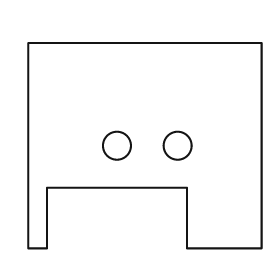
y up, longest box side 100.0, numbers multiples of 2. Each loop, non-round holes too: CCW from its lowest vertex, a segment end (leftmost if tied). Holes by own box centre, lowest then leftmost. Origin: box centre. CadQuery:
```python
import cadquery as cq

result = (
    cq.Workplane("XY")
    .moveTo(-50.0, -44.0)
    .lineTo(-42.0, -44.0)
    .lineTo(-42.0, -18.0)
    .lineTo(18.0, -18.0)
    .lineTo(18.0, -44.0)
    .lineTo(50.0, -44.0)
    .lineTo(50.0, 44.0)
    .lineTo(-50.0, 44.0)
    .close()
    .moveTo(-12.0, 0.0)
    .circle(6.0)
    .moveTo(14.0, 0.0)
    .circle(6.0)
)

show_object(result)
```